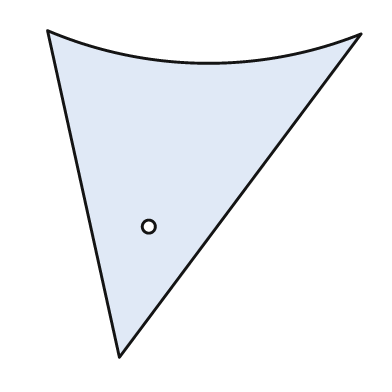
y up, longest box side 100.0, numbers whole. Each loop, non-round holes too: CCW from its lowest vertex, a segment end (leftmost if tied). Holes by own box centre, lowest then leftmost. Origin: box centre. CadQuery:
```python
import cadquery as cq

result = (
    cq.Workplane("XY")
    .moveTo(-26.0, -50.0)
    .lineTo(48.0, 49.0)
    .threePointArc((0.0, 40.0), (-48.0, 50.0))
    .close()
    .moveTo(-17.0, -10.0)
    .circle(2.0)
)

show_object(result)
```